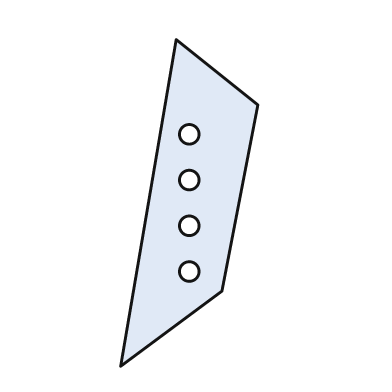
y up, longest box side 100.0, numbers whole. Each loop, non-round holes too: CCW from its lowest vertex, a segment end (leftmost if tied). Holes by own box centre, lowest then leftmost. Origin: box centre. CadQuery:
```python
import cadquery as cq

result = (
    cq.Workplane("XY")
    .moveTo(-21.0, -50.0)
    .lineTo(10.0, -27.0)
    .lineTo(21.0, 30.0)
    .lineTo(-4.0, 50.0)
    .close()
    .moveTo(0.0, -21.0)
    .circle(3.0)
    .moveTo(0.0, -7.0)
    .circle(3.0)
    .moveTo(0.0, 7.0)
    .circle(3.0)
    .moveTo(0.0, 21.0)
    .circle(3.0)
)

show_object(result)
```